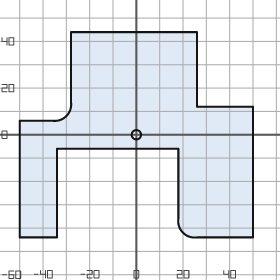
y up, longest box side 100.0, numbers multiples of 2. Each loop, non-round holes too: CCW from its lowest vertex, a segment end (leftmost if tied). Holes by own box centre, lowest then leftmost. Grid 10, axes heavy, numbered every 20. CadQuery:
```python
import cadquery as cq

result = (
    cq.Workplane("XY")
    .moveTo(-50.0, -44.0)
    .lineTo(-34.0, -44.0)
    .lineTo(-34.0, -6.0)
    .lineTo(18.0, -6.0)
    .lineTo(18.0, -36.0)
    .threePointArc((20.0, -42.0), (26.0, -44.0))
    .lineTo(50.0, -44.0)
    .lineTo(50.0, 12.0)
    .lineTo(26.0, 12.0)
    .lineTo(26.0, 44.0)
    .lineTo(-28.0, 44.0)
    .lineTo(-28.0, 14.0)
    .threePointArc((-30.0, 8.0), (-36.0, 6.0))
    .lineTo(-50.0, 6.0)
    .close()
    .moveTo(0.0, 0.0)
    .circle(2.0)
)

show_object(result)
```